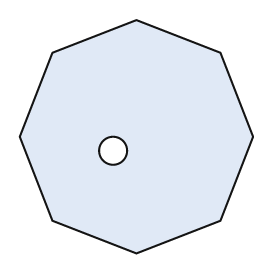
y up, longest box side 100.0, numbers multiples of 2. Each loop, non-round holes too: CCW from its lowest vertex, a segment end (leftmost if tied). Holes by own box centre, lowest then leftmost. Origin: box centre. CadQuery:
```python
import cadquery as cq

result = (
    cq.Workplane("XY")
    .moveTo(0.0, -50.0)
    .lineTo(36.0, -36.0)
    .lineTo(50.0, 0.0)
    .lineTo(36.0, 36.0)
    .lineTo(0.0, 50.0)
    .lineTo(-36.0, 36.0)
    .lineTo(-50.0, 0.0)
    .lineTo(-36.0, -36.0)
    .close()
    .moveTo(-10.0, -6.0)
    .circle(6.0)
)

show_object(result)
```